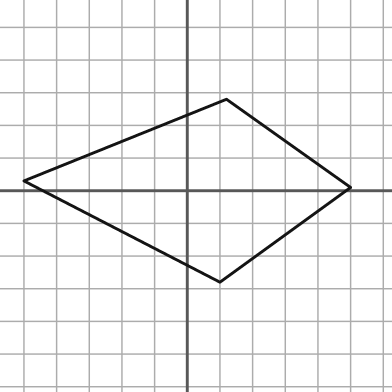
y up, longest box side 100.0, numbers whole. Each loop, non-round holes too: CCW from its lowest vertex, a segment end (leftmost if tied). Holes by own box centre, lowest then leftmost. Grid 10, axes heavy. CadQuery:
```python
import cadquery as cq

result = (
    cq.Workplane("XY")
    .moveTo(10.0, -28.0)
    .lineTo(50.0, 1.0)
    .lineTo(12.0, 28.0)
    .lineTo(-50.0, 3.0)
    .close()
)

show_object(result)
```